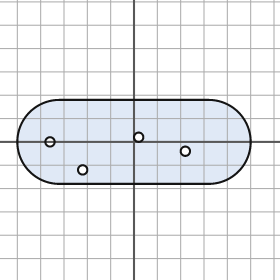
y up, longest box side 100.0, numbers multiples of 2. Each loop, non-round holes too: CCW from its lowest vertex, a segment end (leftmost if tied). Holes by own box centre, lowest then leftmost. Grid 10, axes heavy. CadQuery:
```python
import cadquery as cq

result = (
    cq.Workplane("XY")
    .moveTo(-32.0, -18.0)
    .lineTo(32.0, -18.0)
    .threePointArc((50.0, 0.0), (32.0, 18.0))
    .lineTo(-32.0, 18.0)
    .threePointArc((-50.0, 0.0), (-32.0, -18.0))
    .close()
    .moveTo(-22.0, -12.0)
    .circle(2.0)
    .moveTo(22.0, -4.0)
    .circle(2.0)
    .moveTo(-36.0, 0.0)
    .circle(2.0)
    .moveTo(2.0, 2.0)
    .circle(2.0)
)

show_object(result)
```